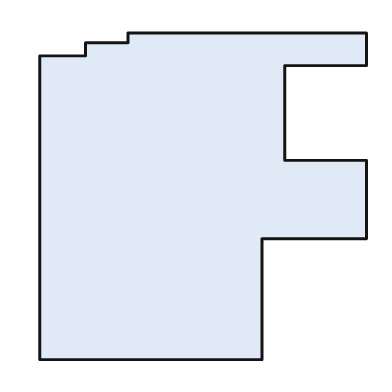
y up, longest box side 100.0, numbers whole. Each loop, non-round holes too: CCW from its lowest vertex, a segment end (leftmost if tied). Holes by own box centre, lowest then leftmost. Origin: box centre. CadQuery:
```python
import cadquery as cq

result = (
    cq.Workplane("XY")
    .moveTo(-50.0, -50.0)
    .lineTo(18.0, -50.0)
    .lineTo(18.0, -13.0)
    .lineTo(50.0, -13.0)
    .lineTo(50.0, 11.0)
    .lineTo(25.0, 11.0)
    .lineTo(25.0, 40.0)
    .lineTo(50.0, 40.0)
    .lineTo(50.0, 50.0)
    .lineTo(-23.0, 50.0)
    .lineTo(-23.0, 47.0)
    .lineTo(-36.0, 47.0)
    .lineTo(-36.0, 43.0)
    .lineTo(-50.0, 43.0)
    .close()
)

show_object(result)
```